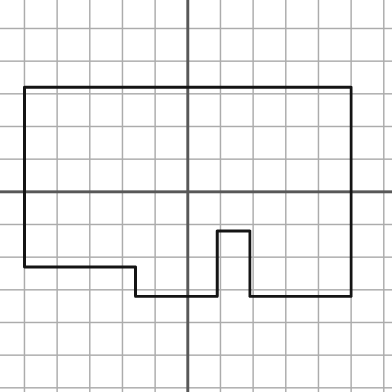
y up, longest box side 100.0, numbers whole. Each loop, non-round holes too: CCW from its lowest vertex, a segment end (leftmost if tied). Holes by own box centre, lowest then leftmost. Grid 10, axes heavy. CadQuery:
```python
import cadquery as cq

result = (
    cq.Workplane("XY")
    .moveTo(-16.0, -32.0)
    .lineTo(9.0, -32.0)
    .lineTo(9.0, -12.0)
    .lineTo(19.0, -12.0)
    .lineTo(19.0, -32.0)
    .lineTo(50.0, -32.0)
    .lineTo(50.0, 32.0)
    .lineTo(-50.0, 32.0)
    .lineTo(-50.0, -23.0)
    .lineTo(-16.0, -23.0)
    .close()
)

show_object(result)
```